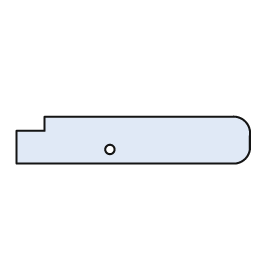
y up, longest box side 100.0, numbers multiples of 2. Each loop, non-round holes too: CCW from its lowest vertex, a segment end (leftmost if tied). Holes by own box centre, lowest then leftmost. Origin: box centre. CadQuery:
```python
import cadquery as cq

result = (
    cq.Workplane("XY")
    .moveTo(-50.0, -10.0)
    .lineTo(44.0, -10.0)
    .threePointArc((48.0, -8.0), (50.0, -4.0))
    .lineTo(50.0, 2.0)
    .threePointArc((48.0, 8.0), (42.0, 10.0))
    .lineTo(-38.0, 10.0)
    .lineTo(-38.0, 4.0)
    .lineTo(-50.0, 4.0)
    .close()
    .moveTo(-10.0, -4.0)
    .circle(2.0)
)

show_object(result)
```